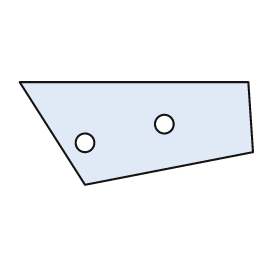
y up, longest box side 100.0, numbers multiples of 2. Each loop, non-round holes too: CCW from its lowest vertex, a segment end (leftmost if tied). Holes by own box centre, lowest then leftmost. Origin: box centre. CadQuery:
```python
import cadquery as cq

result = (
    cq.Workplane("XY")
    .moveTo(-22.0, -22.0)
    .lineTo(50.0, -8.0)
    .lineTo(48.0, 22.0)
    .lineTo(-50.0, 22.0)
    .close()
    .moveTo(-22.0, -4.0)
    .circle(4.0)
    .moveTo(12.0, 4.0)
    .circle(4.0)
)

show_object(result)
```